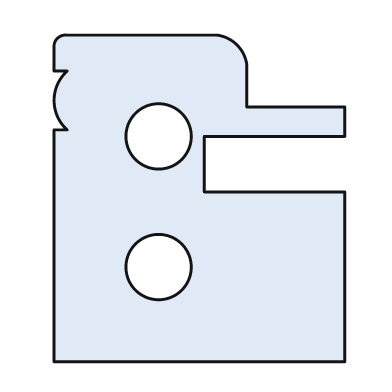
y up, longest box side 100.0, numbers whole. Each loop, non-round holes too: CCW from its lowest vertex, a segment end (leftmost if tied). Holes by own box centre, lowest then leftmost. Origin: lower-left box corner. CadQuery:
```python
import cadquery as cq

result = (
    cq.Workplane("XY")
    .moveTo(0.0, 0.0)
    .lineTo(89.0, 0.0)
    .lineTo(89.0, 52.0)
    .lineTo(46.0, 52.0)
    .lineTo(46.0, 69.0)
    .lineTo(89.0, 69.0)
    .lineTo(89.0, 78.0)
    .lineTo(59.0, 78.0)
    .lineTo(59.0, 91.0)
    .threePointArc((56.0, 97.0), (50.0, 100.0))
    .lineTo(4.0, 100.0)
    .threePointArc((1.0, 99.0), (0.0, 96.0))
    .lineTo(0.0, 89.0)
    .lineTo(4.0, 89.0)
    .threePointArc((0.0, 80.0), (4.0, 71.0))
    .lineTo(0.0, 71.0)
    .close()
    .moveTo(32.0, 29.0)
    .circle(10.0)
    .moveTo(32.0, 69.0)
    .circle(10.0)
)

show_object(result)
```